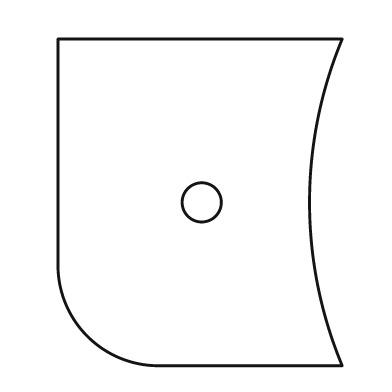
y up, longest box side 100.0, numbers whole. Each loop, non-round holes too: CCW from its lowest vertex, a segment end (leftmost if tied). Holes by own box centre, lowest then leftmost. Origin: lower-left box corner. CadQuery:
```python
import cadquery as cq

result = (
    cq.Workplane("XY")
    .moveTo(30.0, 0.0)
    .lineTo(87.0, 0.0)
    .threePointArc((77.0, 50.0), (87.0, 100.0))
    .lineTo(0.0, 100.0)
    .lineTo(0.0, 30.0)
    .threePointArc((9.0, 9.0), (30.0, 0.0))
    .close()
    .moveTo(44.0, 50.0)
    .circle(6.0)
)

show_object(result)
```